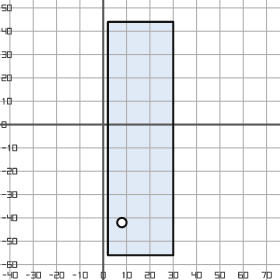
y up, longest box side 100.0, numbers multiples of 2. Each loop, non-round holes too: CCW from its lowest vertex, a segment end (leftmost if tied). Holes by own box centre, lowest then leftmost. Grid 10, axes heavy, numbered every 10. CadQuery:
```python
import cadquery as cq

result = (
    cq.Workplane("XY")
    .moveTo(2.0, -56.0)
    .lineTo(30.0, -56.0)
    .lineTo(30.0, 44.0)
    .lineTo(2.0, 44.0)
    .close()
    .moveTo(8.0, -42.0)
    .circle(2.0)
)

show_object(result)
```